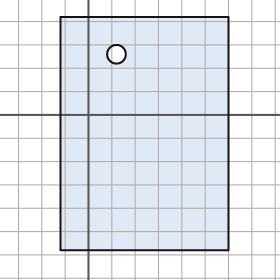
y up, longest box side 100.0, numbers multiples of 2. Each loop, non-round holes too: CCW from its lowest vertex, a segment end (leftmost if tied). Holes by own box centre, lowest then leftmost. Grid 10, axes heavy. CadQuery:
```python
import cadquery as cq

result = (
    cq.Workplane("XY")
    .moveTo(-12.0, -58.0)
    .lineTo(60.0, -58.0)
    .lineTo(60.0, 42.0)
    .lineTo(-12.0, 42.0)
    .close()
    .moveTo(12.0, 26.0)
    .circle(4.0)
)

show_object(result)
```